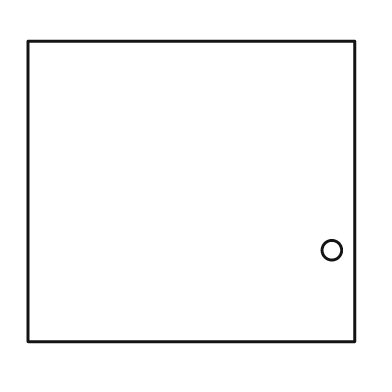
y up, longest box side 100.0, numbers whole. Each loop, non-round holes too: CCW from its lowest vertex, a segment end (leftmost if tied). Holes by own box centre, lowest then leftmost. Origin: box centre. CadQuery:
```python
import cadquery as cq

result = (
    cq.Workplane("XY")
    .moveTo(-50.0, -46.0)
    .lineTo(50.0, -46.0)
    .lineTo(50.0, 46.0)
    .lineTo(-50.0, 46.0)
    .close()
    .moveTo(43.0, -18.0)
    .circle(3.0)
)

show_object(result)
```